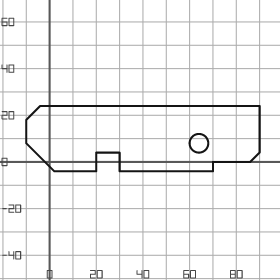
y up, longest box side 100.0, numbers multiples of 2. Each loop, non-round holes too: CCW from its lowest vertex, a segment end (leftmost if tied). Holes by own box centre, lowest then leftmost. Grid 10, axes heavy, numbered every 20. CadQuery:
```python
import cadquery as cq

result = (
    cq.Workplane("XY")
    .moveTo(2.0, -4.0)
    .lineTo(20.0, -4.0)
    .lineTo(20.0, 4.0)
    .lineTo(30.0, 4.0)
    .lineTo(30.0, -4.0)
    .lineTo(70.0, -4.0)
    .lineTo(70.0, 0.0)
    .lineTo(86.0, 0.0)
    .lineTo(90.0, 4.0)
    .lineTo(90.0, 24.0)
    .lineTo(-4.0, 24.0)
    .lineTo(-10.0, 18.0)
    .lineTo(-10.0, 8.0)
    .close()
    .moveTo(64.0, 8.0)
    .circle(4.0)
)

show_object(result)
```